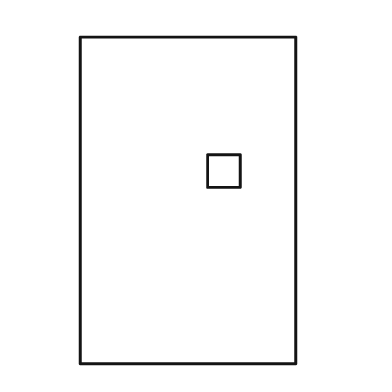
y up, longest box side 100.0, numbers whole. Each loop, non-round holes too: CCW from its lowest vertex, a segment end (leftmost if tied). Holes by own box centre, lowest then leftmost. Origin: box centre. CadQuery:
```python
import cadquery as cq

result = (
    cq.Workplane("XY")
    .moveTo(-33.0, -50.0)
    .lineTo(33.0, -50.0)
    .lineTo(33.0, 50.0)
    .lineTo(-33.0, 50.0)
    .close()
    .moveTo(6.0, 4.0)
    .lineTo(16.0, 4.0)
    .lineTo(16.0, 14.0)
    .lineTo(6.0, 14.0)
    .close()
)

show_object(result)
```